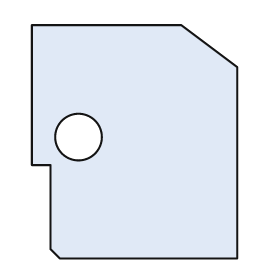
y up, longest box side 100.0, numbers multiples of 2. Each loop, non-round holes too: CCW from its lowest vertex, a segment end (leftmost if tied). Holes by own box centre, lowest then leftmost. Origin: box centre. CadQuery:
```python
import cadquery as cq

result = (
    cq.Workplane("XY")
    .moveTo(-32.0, -50.0)
    .lineTo(44.0, -50.0)
    .lineTo(44.0, 32.0)
    .lineTo(20.0, 50.0)
    .lineTo(-44.0, 50.0)
    .lineTo(-44.0, -10.0)
    .lineTo(-36.0, -10.0)
    .lineTo(-36.0, -46.0)
    .close()
    .moveTo(-24.0, 2.0)
    .circle(10.0)
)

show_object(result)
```